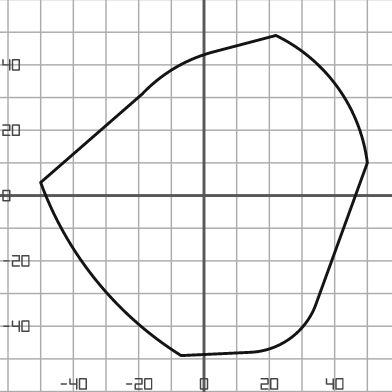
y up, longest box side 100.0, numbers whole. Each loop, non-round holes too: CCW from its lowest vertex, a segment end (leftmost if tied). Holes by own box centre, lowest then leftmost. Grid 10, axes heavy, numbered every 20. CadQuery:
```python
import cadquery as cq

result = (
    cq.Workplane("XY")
    .moveTo(-7.0, -49.0)
    .lineTo(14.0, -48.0)
    .threePointArc((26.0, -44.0), (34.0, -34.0))
    .lineTo(50.0, 10.0)
    .threePointArc((41.0, 33.0), (22.0, 49.0))
    .lineTo(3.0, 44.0)
    .threePointArc((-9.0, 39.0), (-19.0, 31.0))
    .lineTo(-50.0, 4.0)
    .threePointArc((-33.0, -26.0), (-7.0, -49.0))
    .close()
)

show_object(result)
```